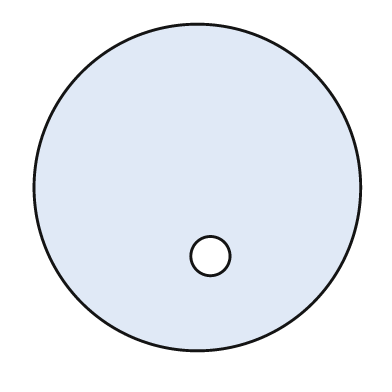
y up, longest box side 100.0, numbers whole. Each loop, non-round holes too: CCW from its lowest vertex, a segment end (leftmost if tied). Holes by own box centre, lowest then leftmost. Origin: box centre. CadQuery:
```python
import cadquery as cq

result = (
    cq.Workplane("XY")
    .moveTo(0.0, 0.0)
    .circle(50.0)
    .moveTo(4.0, -21.0)
    .circle(6.0)
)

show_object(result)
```